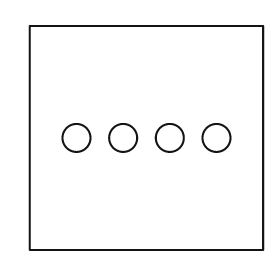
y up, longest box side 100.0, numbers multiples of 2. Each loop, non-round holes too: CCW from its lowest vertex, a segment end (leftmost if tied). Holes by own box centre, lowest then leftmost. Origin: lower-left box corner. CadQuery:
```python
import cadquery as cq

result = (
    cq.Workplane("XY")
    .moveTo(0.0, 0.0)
    .lineTo(100.0, 0.0)
    .lineTo(100.0, 96.0)
    .lineTo(0.0, 96.0)
    .close()
    .moveTo(20.0, 48.0)
    .circle(6.0)
    .moveTo(40.0, 48.0)
    .circle(6.0)
    .moveTo(60.0, 48.0)
    .circle(6.0)
    .moveTo(80.0, 48.0)
    .circle(6.0)
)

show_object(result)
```